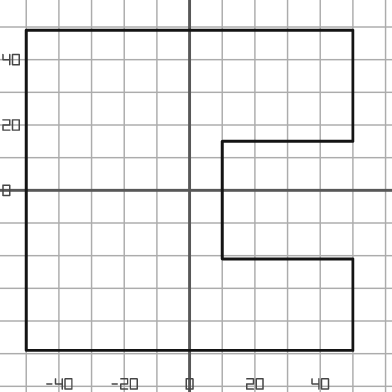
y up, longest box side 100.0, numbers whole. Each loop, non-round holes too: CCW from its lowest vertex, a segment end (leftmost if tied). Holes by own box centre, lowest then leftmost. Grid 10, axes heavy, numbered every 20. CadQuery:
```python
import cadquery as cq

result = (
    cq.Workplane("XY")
    .moveTo(-50.0, -49.0)
    .lineTo(50.0, -49.0)
    .lineTo(50.0, -21.0)
    .lineTo(10.0, -21.0)
    .lineTo(10.0, 15.0)
    .lineTo(50.0, 15.0)
    .lineTo(50.0, 49.0)
    .lineTo(-50.0, 49.0)
    .close()
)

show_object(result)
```